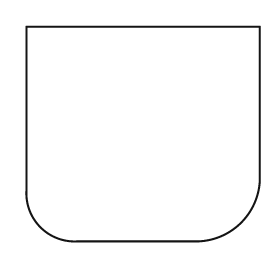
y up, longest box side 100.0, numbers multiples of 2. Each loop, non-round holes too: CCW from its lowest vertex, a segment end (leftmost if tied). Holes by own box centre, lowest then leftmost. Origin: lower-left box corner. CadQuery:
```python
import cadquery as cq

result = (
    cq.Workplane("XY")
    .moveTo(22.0, 0.0)
    .lineTo(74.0, 0.0)
    .threePointArc((92.0, 8.0), (100.0, 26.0))
    .lineTo(100.0, 92.0)
    .lineTo(0.0, 92.0)
    .lineTo(0.0, 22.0)
    .threePointArc((6.0, 6.0), (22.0, 0.0))
    .close()
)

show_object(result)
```